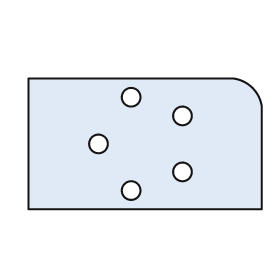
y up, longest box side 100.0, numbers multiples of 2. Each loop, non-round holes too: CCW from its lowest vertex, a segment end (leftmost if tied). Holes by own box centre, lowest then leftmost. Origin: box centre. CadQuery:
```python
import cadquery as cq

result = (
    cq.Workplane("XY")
    .moveTo(-50.0, -28.0)
    .lineTo(50.0, -28.0)
    .lineTo(50.0, 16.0)
    .threePointArc((46.0, 24.0), (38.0, 28.0))
    .lineTo(-50.0, 28.0)
    .close()
    .moveTo(-6.0, -20.0)
    .circle(4.0)
    .moveTo(16.0, -12.0)
    .circle(4.0)
    .moveTo(-20.0, 0.0)
    .circle(4.0)
    .moveTo(16.0, 12.0)
    .circle(4.0)
    .moveTo(-6.0, 20.0)
    .circle(4.0)
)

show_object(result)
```